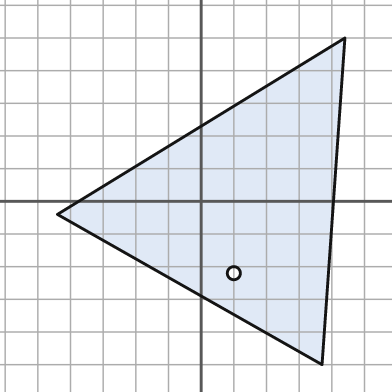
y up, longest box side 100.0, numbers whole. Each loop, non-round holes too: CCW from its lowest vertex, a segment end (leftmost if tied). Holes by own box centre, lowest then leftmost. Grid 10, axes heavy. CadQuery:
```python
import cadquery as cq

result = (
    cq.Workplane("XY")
    .moveTo(37.0, -50.0)
    .lineTo(44.0, 50.0)
    .lineTo(-44.0, -4.0)
    .close()
    .moveTo(10.0, -22.0)
    .circle(2.0)
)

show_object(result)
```